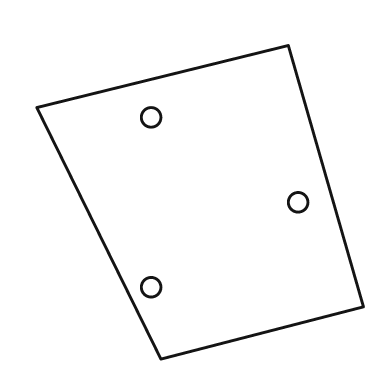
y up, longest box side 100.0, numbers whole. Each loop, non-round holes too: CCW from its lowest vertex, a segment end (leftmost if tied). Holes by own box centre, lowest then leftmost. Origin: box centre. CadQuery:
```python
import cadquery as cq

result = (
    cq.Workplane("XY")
    .moveTo(-12.0, -48.0)
    .lineTo(50.0, -32.0)
    .lineTo(27.0, 48.0)
    .lineTo(-50.0, 29.0)
    .close()
    .moveTo(-15.0, -26.0)
    .circle(3.0)
    .moveTo(30.0, 0.0)
    .circle(3.0)
    .moveTo(-15.0, 26.0)
    .circle(3.0)
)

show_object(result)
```